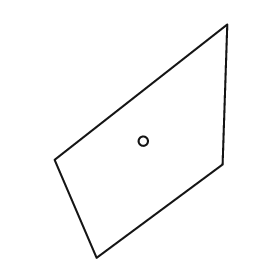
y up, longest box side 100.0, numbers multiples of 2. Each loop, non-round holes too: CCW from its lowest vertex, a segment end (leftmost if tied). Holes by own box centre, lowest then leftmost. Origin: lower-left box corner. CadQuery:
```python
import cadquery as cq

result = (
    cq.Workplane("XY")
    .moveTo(18.0, 0.0)
    .lineTo(72.0, 40.0)
    .lineTo(74.0, 100.0)
    .lineTo(0.0, 42.0)
    .close()
    .moveTo(38.0, 50.0)
    .circle(2.0)
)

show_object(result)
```